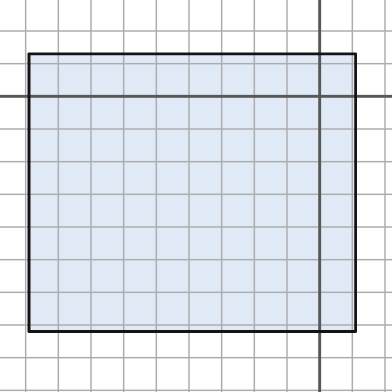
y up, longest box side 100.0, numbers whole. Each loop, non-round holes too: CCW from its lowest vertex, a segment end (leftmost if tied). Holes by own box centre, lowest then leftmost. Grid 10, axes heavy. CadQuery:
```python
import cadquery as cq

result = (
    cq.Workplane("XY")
    .moveTo(-89.0, -72.0)
    .lineTo(11.0, -72.0)
    .lineTo(11.0, 13.0)
    .lineTo(-89.0, 13.0)
    .close()
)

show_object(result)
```